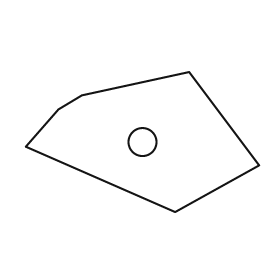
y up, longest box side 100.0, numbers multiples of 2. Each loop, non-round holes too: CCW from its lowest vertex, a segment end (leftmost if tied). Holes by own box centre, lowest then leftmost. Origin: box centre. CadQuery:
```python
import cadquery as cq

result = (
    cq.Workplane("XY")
    .moveTo(14.0, -30.0)
    .lineTo(50.0, -10.0)
    .lineTo(20.0, 30.0)
    .lineTo(-26.0, 20.0)
    .lineTo(-36.0, 14.0)
    .lineTo(-50.0, -2.0)
    .close()
    .moveTo(0.0, 0.0)
    .circle(6.0)
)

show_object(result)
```